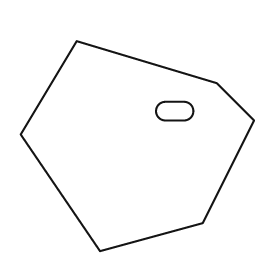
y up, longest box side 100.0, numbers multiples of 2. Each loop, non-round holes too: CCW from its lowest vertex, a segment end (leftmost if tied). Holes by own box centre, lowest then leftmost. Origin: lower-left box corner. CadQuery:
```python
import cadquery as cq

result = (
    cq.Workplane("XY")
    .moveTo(34.0, 0.0)
    .lineTo(78.0, 12.0)
    .lineTo(100.0, 56.0)
    .lineTo(84.0, 72.0)
    .lineTo(24.0, 90.0)
    .lineTo(0.0, 50.0)
    .close()
    .moveTo(62.0, 56.0)
    .lineTo(70.0, 56.0)
    .threePointArc((74.0, 60.0), (70.0, 64.0))
    .lineTo(62.0, 64.0)
    .threePointArc((58.0, 60.0), (62.0, 56.0))
    .close()
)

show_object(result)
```